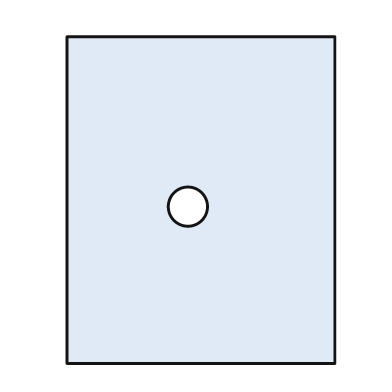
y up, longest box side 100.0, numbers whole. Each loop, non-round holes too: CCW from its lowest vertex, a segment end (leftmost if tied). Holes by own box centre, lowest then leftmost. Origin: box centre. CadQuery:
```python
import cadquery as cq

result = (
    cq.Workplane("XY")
    .moveTo(-41.0, -50.0)
    .lineTo(41.0, -50.0)
    .lineTo(41.0, 50.0)
    .lineTo(-41.0, 50.0)
    .close()
    .moveTo(-4.0, -2.0)
    .circle(6.0)
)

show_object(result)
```